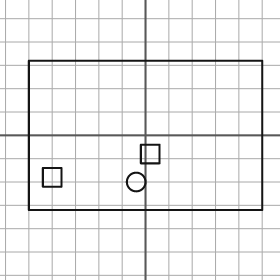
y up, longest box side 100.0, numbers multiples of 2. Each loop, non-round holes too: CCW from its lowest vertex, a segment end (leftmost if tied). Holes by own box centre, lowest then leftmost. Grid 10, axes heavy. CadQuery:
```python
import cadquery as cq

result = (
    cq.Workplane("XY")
    .moveTo(-50.0, -32.0)
    .lineTo(50.0, -32.0)
    .lineTo(50.0, 32.0)
    .lineTo(-50.0, 32.0)
    .close()
    .moveTo(-4.0, -20.0)
    .circle(4.0)
    .moveTo(-44.0, -22.0)
    .lineTo(-36.0, -22.0)
    .lineTo(-36.0, -14.0)
    .lineTo(-44.0, -14.0)
    .close()
    .moveTo(-2.0, -12.0)
    .lineTo(6.0, -12.0)
    .lineTo(6.0, -4.0)
    .lineTo(-2.0, -4.0)
    .close()
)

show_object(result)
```